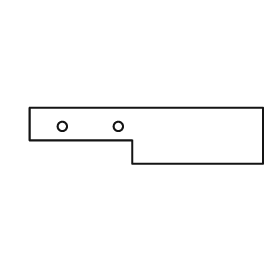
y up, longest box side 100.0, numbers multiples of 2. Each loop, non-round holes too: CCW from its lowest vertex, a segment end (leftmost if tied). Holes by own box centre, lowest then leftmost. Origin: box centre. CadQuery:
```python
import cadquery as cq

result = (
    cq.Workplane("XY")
    .moveTo(-6.0, -12.0)
    .lineTo(50.0, -12.0)
    .lineTo(50.0, 12.0)
    .lineTo(-50.0, 12.0)
    .lineTo(-50.0, -2.0)
    .lineTo(-6.0, -2.0)
    .close()
    .moveTo(-36.0, 4.0)
    .circle(2.0)
    .moveTo(-12.0, 4.0)
    .circle(2.0)
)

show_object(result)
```